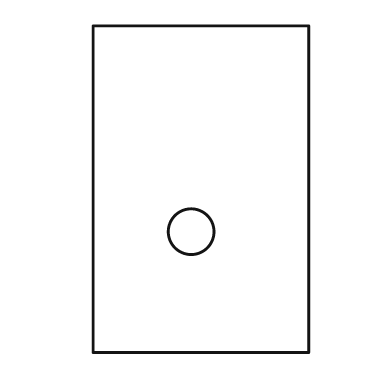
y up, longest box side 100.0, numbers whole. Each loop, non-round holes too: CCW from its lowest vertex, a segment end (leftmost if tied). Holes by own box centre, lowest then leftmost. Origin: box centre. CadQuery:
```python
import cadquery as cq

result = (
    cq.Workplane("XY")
    .moveTo(-33.0, -50.0)
    .lineTo(33.0, -50.0)
    .lineTo(33.0, 50.0)
    .lineTo(-33.0, 50.0)
    .close()
    .moveTo(-3.0, -13.0)
    .circle(7.0)
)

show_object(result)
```